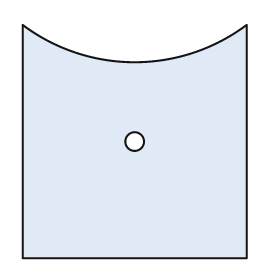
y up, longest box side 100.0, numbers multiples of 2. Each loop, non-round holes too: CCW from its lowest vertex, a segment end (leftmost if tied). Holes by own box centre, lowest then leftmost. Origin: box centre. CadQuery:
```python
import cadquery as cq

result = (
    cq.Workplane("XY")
    .moveTo(-48.0, -50.0)
    .lineTo(48.0, -50.0)
    .lineTo(48.0, 50.0)
    .threePointArc((0.0, 34.0), (-48.0, 50.0))
    .close()
    .moveTo(0.0, 0.0)
    .circle(4.0)
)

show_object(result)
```